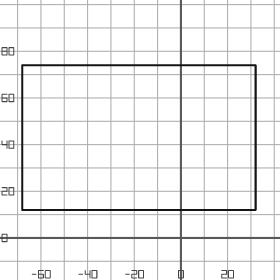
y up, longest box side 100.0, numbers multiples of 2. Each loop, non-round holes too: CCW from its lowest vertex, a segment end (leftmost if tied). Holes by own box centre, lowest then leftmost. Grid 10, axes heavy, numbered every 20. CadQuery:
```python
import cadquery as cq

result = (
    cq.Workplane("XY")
    .moveTo(-68.0, 12.0)
    .lineTo(32.0, 12.0)
    .lineTo(32.0, 74.0)
    .lineTo(-68.0, 74.0)
    .close()
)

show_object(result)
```